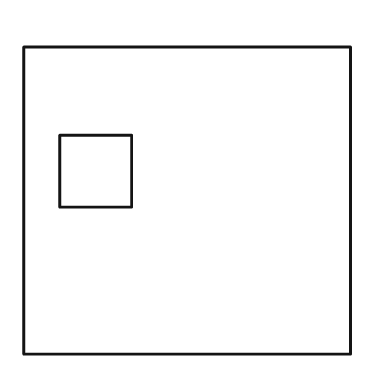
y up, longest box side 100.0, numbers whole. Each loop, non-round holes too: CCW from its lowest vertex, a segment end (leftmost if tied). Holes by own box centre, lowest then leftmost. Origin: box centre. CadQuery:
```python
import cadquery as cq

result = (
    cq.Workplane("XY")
    .moveTo(-50.0, -47.0)
    .lineTo(50.0, -47.0)
    .lineTo(50.0, 47.0)
    .lineTo(-50.0, 47.0)
    .close()
    .moveTo(-39.0, -2.0)
    .lineTo(-17.0, -2.0)
    .lineTo(-17.0, 20.0)
    .lineTo(-39.0, 20.0)
    .close()
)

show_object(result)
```